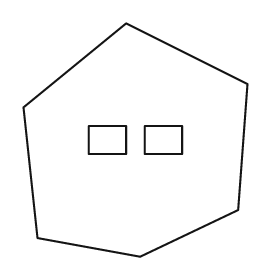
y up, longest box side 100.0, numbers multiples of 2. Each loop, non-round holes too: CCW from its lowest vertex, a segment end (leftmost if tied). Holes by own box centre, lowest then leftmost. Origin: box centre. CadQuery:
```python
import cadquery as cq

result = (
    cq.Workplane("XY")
    .moveTo(2.0, -50.0)
    .lineTo(44.0, -30.0)
    .lineTo(48.0, 24.0)
    .lineTo(-4.0, 50.0)
    .lineTo(-48.0, 14.0)
    .lineTo(-42.0, -42.0)
    .close()
    .moveTo(-20.0, -6.0)
    .lineTo(-4.0, -6.0)
    .lineTo(-4.0, 6.0)
    .lineTo(-20.0, 6.0)
    .close()
    .moveTo(4.0, -6.0)
    .lineTo(20.0, -6.0)
    .lineTo(20.0, 6.0)
    .lineTo(4.0, 6.0)
    .close()
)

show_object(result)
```